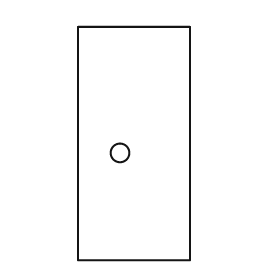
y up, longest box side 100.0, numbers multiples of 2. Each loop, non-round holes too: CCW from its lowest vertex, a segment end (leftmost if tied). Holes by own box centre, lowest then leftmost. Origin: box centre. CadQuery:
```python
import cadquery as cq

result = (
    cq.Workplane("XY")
    .moveTo(-24.0, -50.0)
    .lineTo(24.0, -50.0)
    .lineTo(24.0, 50.0)
    .lineTo(-24.0, 50.0)
    .close()
    .moveTo(-6.0, -4.0)
    .circle(4.0)
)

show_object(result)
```